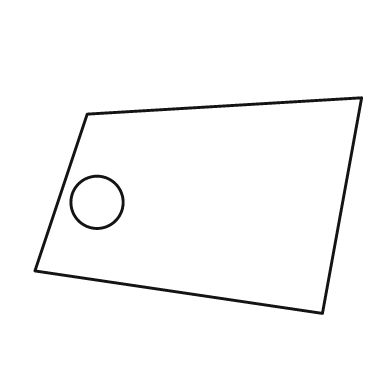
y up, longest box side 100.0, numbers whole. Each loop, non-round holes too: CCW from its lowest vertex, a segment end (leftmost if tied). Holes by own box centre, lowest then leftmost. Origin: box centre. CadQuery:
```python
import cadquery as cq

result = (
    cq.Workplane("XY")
    .moveTo(38.0, -33.0)
    .lineTo(50.0, 33.0)
    .lineTo(-34.0, 28.0)
    .lineTo(-50.0, -20.0)
    .close()
    .moveTo(-31.0, 1.0)
    .circle(8.0)
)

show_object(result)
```